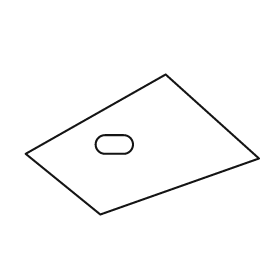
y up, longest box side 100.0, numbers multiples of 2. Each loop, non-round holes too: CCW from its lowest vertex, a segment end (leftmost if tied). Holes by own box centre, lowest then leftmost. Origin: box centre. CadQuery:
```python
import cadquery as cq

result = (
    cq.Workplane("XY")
    .moveTo(-18.0, -30.0)
    .lineTo(50.0, -6.0)
    .lineTo(10.0, 30.0)
    .lineTo(-50.0, -4.0)
    .close()
    .moveTo(-16.0, -4.0)
    .lineTo(-8.0, -4.0)
    .threePointArc((-4.0, 0.0), (-8.0, 4.0))
    .lineTo(-16.0, 4.0)
    .threePointArc((-20.0, 0.0), (-16.0, -4.0))
    .close()
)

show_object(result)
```